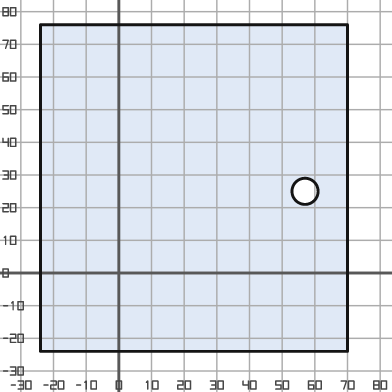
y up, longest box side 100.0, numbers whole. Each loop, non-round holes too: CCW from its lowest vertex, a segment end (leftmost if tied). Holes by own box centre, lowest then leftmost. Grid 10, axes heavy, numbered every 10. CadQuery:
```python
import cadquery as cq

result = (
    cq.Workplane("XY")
    .moveTo(-24.0, -24.0)
    .lineTo(70.0, -24.0)
    .lineTo(70.0, 76.0)
    .lineTo(-24.0, 76.0)
    .close()
    .moveTo(57.0, 25.0)
    .circle(4.0)
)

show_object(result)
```